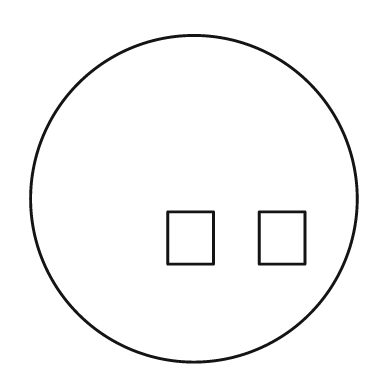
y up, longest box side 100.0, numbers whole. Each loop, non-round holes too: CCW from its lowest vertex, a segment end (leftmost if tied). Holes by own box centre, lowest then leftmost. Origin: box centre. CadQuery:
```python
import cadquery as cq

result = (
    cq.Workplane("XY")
    .moveTo(0.0, 0.0)
    .circle(50.0)
    .moveTo(-8.0, -20.0)
    .lineTo(6.0, -20.0)
    .lineTo(6.0, -4.0)
    .lineTo(-8.0, -4.0)
    .close()
    .moveTo(20.0, -20.0)
    .lineTo(34.0, -20.0)
    .lineTo(34.0, -4.0)
    .lineTo(20.0, -4.0)
    .close()
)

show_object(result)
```